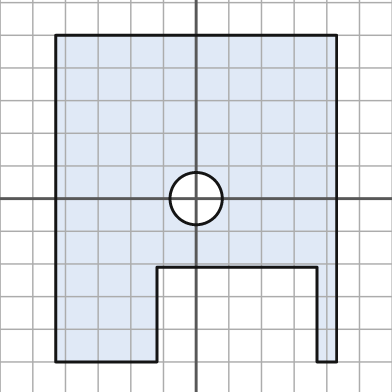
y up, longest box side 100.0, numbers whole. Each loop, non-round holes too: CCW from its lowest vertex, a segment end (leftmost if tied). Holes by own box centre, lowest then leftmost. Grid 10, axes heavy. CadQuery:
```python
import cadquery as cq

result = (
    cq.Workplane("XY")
    .moveTo(-43.0, -50.0)
    .lineTo(-12.0, -50.0)
    .lineTo(-12.0, -21.0)
    .lineTo(37.0, -21.0)
    .lineTo(37.0, -50.0)
    .lineTo(43.0, -50.0)
    .lineTo(43.0, 50.0)
    .lineTo(-43.0, 50.0)
    .close()
    .moveTo(0.0, 0.0)
    .circle(8.0)
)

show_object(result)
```